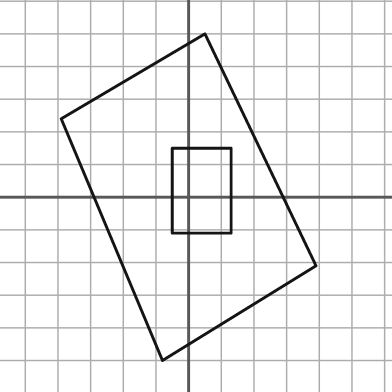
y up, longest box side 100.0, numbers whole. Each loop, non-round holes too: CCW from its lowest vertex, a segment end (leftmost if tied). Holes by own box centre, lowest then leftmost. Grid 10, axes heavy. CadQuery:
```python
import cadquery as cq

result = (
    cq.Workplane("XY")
    .moveTo(-8.0, -50.0)
    .lineTo(39.0, -21.0)
    .lineTo(5.0, 50.0)
    .lineTo(-39.0, 24.0)
    .close()
    .moveTo(-5.0, -11.0)
    .lineTo(13.0, -11.0)
    .lineTo(13.0, 15.0)
    .lineTo(-5.0, 15.0)
    .close()
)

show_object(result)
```